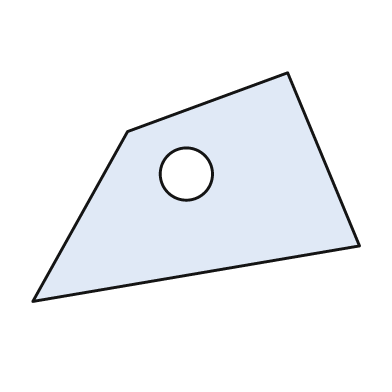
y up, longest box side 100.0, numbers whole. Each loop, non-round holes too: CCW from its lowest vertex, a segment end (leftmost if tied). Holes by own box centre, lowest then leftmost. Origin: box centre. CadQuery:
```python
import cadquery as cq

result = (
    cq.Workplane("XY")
    .moveTo(-50.0, -35.0)
    .lineTo(50.0, -18.0)
    .lineTo(28.0, 35.0)
    .lineTo(-21.0, 17.0)
    .close()
    .moveTo(-3.0, 4.0)
    .circle(8.0)
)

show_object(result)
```